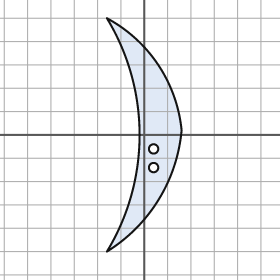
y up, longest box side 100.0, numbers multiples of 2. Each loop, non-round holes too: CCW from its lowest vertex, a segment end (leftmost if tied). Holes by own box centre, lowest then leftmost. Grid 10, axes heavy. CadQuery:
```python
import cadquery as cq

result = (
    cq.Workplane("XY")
    .moveTo(-16.0, -50.0)
    .threePointArc((6.0, -28.0), (16.0, 2.0))
    .threePointArc((6.0, 30.0), (-16.0, 50.0))
    .threePointArc((-2.0, 0.0), (-16.0, -50.0))
    .close()
    .moveTo(4.0, -14.0)
    .circle(2.0)
    .moveTo(4.0, -6.0)
    .circle(2.0)
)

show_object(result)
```